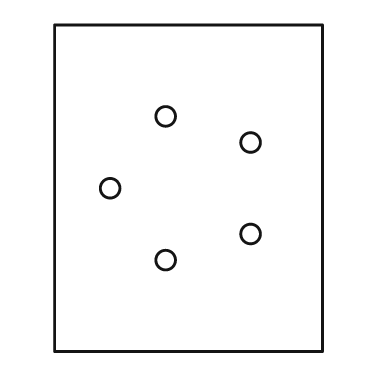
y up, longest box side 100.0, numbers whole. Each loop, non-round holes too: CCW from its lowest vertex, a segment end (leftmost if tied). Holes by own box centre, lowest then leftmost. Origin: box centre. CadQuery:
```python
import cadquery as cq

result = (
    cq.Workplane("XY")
    .moveTo(-41.0, -50.0)
    .lineTo(41.0, -50.0)
    .lineTo(41.0, 50.0)
    .lineTo(-41.0, 50.0)
    .close()
    .moveTo(-7.0, -22.0)
    .circle(3.0)
    .moveTo(19.0, -14.0)
    .circle(3.0)
    .moveTo(-24.0, 0.0)
    .circle(3.0)
    .moveTo(19.0, 14.0)
    .circle(3.0)
    .moveTo(-7.0, 22.0)
    .circle(3.0)
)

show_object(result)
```